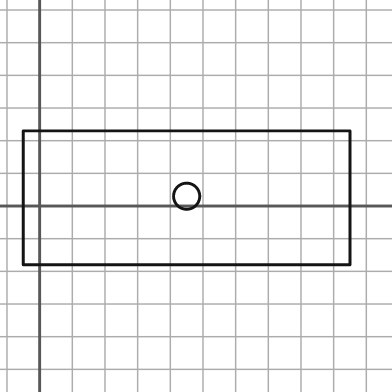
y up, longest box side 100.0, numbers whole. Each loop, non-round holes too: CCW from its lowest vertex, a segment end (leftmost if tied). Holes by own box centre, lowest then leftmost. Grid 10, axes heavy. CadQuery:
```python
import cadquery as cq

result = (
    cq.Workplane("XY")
    .moveTo(-5.0, -18.0)
    .lineTo(95.0, -18.0)
    .lineTo(95.0, 23.0)
    .lineTo(-5.0, 23.0)
    .close()
    .moveTo(45.0, 3.0)
    .circle(4.0)
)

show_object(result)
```